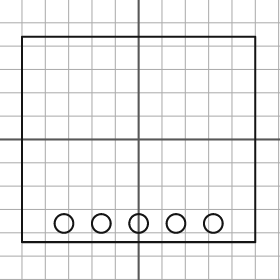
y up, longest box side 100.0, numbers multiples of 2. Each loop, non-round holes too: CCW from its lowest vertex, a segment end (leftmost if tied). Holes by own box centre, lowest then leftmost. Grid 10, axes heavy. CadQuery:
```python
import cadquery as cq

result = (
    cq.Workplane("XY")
    .moveTo(-50.0, -44.0)
    .lineTo(50.0, -44.0)
    .lineTo(50.0, 44.0)
    .lineTo(-50.0, 44.0)
    .close()
    .moveTo(-32.0, -36.0)
    .circle(4.0)
    .moveTo(-16.0, -36.0)
    .circle(4.0)
    .moveTo(0.0, -36.0)
    .circle(4.0)
    .moveTo(16.0, -36.0)
    .circle(4.0)
    .moveTo(32.0, -36.0)
    .circle(4.0)
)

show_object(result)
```